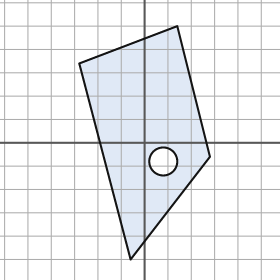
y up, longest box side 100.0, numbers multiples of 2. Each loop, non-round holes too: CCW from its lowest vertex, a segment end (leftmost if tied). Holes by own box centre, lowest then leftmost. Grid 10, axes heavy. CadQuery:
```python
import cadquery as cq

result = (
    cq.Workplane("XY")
    .moveTo(-6.0, -50.0)
    .lineTo(28.0, -6.0)
    .lineTo(14.0, 50.0)
    .lineTo(-28.0, 34.0)
    .close()
    .moveTo(8.0, -8.0)
    .circle(6.0)
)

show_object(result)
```